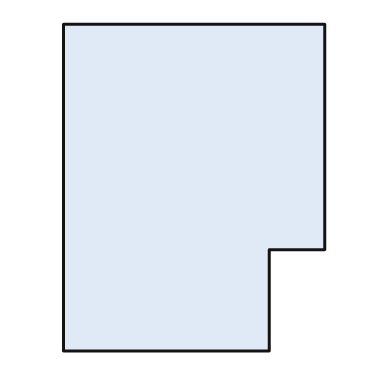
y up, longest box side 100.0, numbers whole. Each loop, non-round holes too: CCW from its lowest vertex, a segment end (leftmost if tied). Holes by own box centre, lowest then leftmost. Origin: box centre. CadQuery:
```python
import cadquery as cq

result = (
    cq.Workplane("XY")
    .moveTo(-40.0, -50.0)
    .lineTo(23.0, -50.0)
    .lineTo(23.0, -19.0)
    .lineTo(40.0, -19.0)
    .lineTo(40.0, 50.0)
    .lineTo(-40.0, 50.0)
    .close()
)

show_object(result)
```